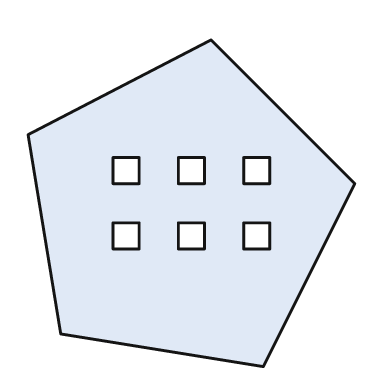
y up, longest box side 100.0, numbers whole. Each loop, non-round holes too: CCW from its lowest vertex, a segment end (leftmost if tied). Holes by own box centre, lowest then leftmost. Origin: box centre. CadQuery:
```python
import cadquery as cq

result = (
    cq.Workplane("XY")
    .moveTo(22.0, -50.0)
    .lineTo(50.0, 6.0)
    .lineTo(6.0, 50.0)
    .lineTo(-50.0, 21.0)
    .lineTo(-40.0, -40.0)
    .close()
    .moveTo(-24.0, -14.0)
    .lineTo(-16.0, -14.0)
    .lineTo(-16.0, -6.0)
    .lineTo(-24.0, -6.0)
    .close()
    .moveTo(-4.0, -14.0)
    .lineTo(4.0, -14.0)
    .lineTo(4.0, -6.0)
    .lineTo(-4.0, -6.0)
    .close()
    .moveTo(16.0, -14.0)
    .lineTo(24.0, -14.0)
    .lineTo(24.0, -6.0)
    .lineTo(16.0, -6.0)
    .close()
    .moveTo(-24.0, 6.0)
    .lineTo(-16.0, 6.0)
    .lineTo(-16.0, 14.0)
    .lineTo(-24.0, 14.0)
    .close()
    .moveTo(-4.0, 6.0)
    .lineTo(4.0, 6.0)
    .lineTo(4.0, 14.0)
    .lineTo(-4.0, 14.0)
    .close()
    .moveTo(16.0, 6.0)
    .lineTo(24.0, 6.0)
    .lineTo(24.0, 14.0)
    .lineTo(16.0, 14.0)
    .close()
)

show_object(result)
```